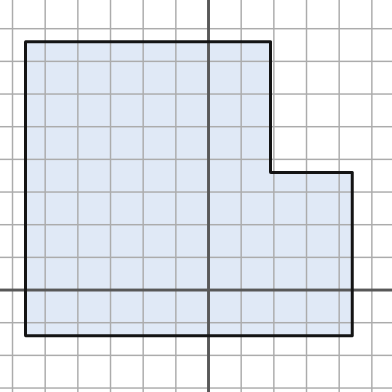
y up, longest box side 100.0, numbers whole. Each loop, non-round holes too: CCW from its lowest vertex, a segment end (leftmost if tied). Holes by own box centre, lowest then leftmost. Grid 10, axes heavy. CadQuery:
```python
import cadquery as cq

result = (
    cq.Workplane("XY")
    .moveTo(-56.0, -14.0)
    .lineTo(44.0, -14.0)
    .lineTo(44.0, 36.0)
    .lineTo(19.0, 36.0)
    .lineTo(19.0, 76.0)
    .lineTo(-56.0, 76.0)
    .close()
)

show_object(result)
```